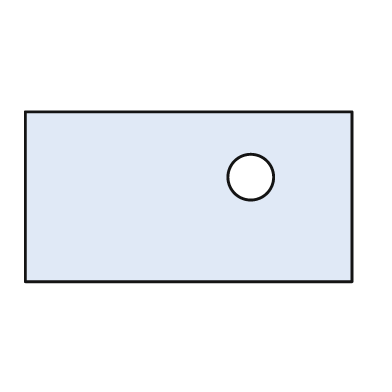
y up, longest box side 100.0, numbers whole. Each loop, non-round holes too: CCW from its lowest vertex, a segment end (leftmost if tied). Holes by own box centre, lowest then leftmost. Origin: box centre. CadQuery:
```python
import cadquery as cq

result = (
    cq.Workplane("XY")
    .moveTo(-50.0, -26.0)
    .lineTo(50.0, -26.0)
    .lineTo(50.0, 26.0)
    .lineTo(-50.0, 26.0)
    .close()
    .moveTo(19.0, 6.0)
    .circle(7.0)
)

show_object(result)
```